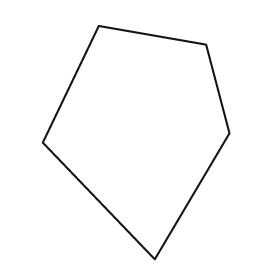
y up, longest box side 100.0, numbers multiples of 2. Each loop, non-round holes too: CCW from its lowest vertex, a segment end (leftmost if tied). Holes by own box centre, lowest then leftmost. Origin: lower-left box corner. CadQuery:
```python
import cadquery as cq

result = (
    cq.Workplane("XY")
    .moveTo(48.0, 0.0)
    .lineTo(80.0, 54.0)
    .lineTo(70.0, 92.0)
    .lineTo(24.0, 100.0)
    .lineTo(0.0, 50.0)
    .close()
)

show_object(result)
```